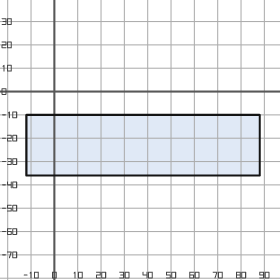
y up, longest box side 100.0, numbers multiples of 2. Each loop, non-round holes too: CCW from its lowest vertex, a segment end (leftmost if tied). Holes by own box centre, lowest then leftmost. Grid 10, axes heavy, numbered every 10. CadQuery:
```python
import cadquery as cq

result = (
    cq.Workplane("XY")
    .moveTo(-12.0, -36.0)
    .lineTo(88.0, -36.0)
    .lineTo(88.0, -10.0)
    .lineTo(-12.0, -10.0)
    .close()
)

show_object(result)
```